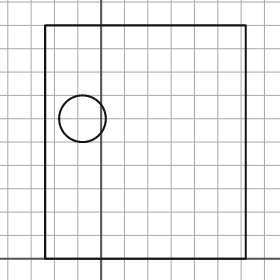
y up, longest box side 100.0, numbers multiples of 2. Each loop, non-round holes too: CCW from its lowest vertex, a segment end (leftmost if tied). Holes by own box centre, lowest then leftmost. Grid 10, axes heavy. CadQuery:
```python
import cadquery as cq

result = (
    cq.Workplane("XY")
    .moveTo(-24.0, 0.0)
    .lineTo(62.0, 0.0)
    .lineTo(62.0, 100.0)
    .lineTo(-24.0, 100.0)
    .close()
    .moveTo(-8.0, 60.0)
    .circle(10.0)
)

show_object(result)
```